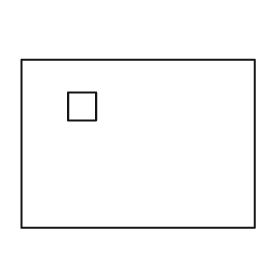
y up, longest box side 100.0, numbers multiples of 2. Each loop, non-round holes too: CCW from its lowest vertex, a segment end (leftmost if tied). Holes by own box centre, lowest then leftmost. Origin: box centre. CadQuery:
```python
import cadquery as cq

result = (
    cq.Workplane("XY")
    .moveTo(-50.0, -36.0)
    .lineTo(50.0, -36.0)
    .lineTo(50.0, 36.0)
    .lineTo(-50.0, 36.0)
    .close()
    .moveTo(-30.0, 10.0)
    .lineTo(-18.0, 10.0)
    .lineTo(-18.0, 22.0)
    .lineTo(-30.0, 22.0)
    .close()
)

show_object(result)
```